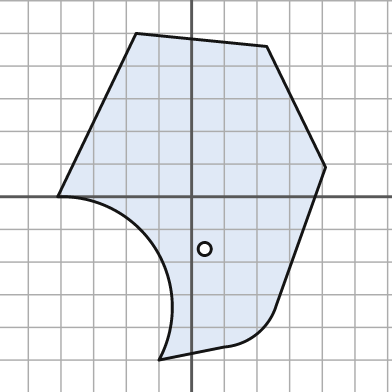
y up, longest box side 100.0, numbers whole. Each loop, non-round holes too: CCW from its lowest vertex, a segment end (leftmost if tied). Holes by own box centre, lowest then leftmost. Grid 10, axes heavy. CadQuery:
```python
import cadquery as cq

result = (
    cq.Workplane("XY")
    .moveTo(-10.0, -50.0)
    .lineTo(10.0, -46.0)
    .threePointArc((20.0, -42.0), (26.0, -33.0))
    .lineTo(41.0, 9.0)
    .lineTo(23.0, 46.0)
    .lineTo(-17.0, 50.0)
    .lineTo(-41.0, 0.0)
    .threePointArc((-11.0, -16.0), (-10.0, -50.0))
    .close()
    .moveTo(4.0, -16.0)
    .circle(2.0)
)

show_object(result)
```